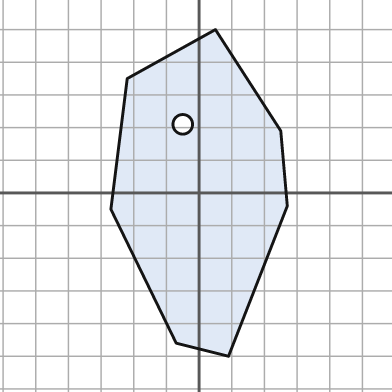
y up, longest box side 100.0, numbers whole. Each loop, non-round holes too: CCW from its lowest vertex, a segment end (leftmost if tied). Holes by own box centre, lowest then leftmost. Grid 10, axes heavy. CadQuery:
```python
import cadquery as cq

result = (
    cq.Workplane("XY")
    .moveTo(9.0, -50.0)
    .lineTo(27.0, -4.0)
    .lineTo(25.0, 19.0)
    .lineTo(5.0, 50.0)
    .lineTo(-22.0, 35.0)
    .lineTo(-27.0, -5.0)
    .lineTo(-7.0, -46.0)
    .close()
    .moveTo(-5.0, 21.0)
    .circle(3.0)
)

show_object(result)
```